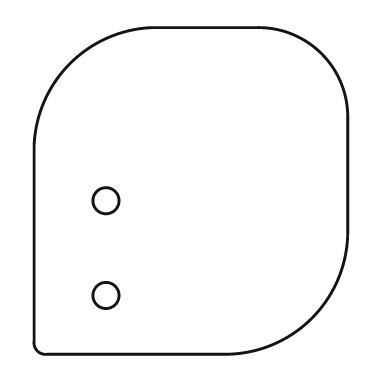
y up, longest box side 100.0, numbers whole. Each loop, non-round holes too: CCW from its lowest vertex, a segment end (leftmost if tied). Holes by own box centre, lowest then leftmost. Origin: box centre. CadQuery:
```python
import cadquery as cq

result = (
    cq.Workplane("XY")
    .moveTo(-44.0, -50.0)
    .lineTo(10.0, -50.0)
    .threePointArc((37.0, -39.0), (48.0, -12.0))
    .lineTo(48.0, 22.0)
    .threePointArc((40.0, 42.0), (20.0, 50.0))
    .lineTo(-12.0, 50.0)
    .threePointArc((-37.0, 39.0), (-48.0, 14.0))
    .lineTo(-48.0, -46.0)
    .threePointArc((-47.0, -49.0), (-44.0, -50.0))
    .close()
    .moveTo(-26.0, -32.0)
    .circle(4.0)
    .moveTo(-26.0, -3.0)
    .circle(4.0)
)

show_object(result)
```